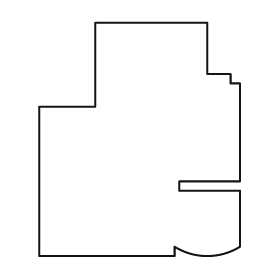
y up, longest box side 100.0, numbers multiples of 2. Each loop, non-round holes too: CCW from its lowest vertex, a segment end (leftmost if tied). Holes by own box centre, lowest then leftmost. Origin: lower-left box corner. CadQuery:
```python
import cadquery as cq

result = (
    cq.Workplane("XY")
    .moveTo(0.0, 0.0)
    .lineTo(58.0, 0.0)
    .lineTo(58.0, 4.0)
    .threePointArc((72.0, 0.0), (86.0, 4.0))
    .lineTo(86.0, 28.0)
    .lineTo(60.0, 28.0)
    .lineTo(60.0, 32.0)
    .lineTo(86.0, 32.0)
    .lineTo(86.0, 74.0)
    .lineTo(82.0, 74.0)
    .lineTo(82.0, 78.0)
    .lineTo(72.0, 78.0)
    .lineTo(72.0, 100.0)
    .lineTo(24.0, 100.0)
    .lineTo(24.0, 64.0)
    .lineTo(0.0, 64.0)
    .close()
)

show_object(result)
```